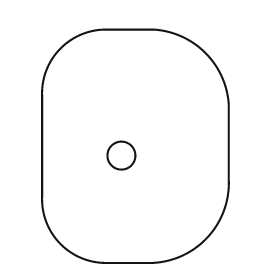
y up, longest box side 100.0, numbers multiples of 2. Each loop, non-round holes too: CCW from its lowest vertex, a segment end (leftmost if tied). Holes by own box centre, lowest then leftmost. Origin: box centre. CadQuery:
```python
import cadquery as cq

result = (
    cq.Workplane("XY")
    .moveTo(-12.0, -50.0)
    .lineTo(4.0, -50.0)
    .threePointArc((30.0, -40.0), (40.0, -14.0))
    .lineTo(40.0, 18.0)
    .threePointArc((30.0, 40.0), (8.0, 50.0))
    .lineTo(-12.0, 50.0)
    .threePointArc((-32.0, 42.0), (-40.0, 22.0))
    .lineTo(-40.0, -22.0)
    .threePointArc((-32.0, -42.0), (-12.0, -50.0))
    .close()
    .moveTo(-6.0, -4.0)
    .circle(6.0)
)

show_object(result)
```